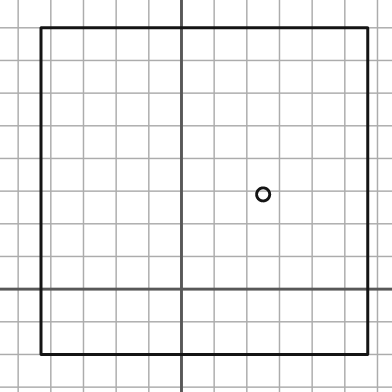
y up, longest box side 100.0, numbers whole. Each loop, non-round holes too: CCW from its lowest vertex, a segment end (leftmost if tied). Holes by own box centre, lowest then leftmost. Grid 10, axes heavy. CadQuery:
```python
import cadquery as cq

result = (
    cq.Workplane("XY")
    .moveTo(-43.0, -20.0)
    .lineTo(57.0, -20.0)
    .lineTo(57.0, 80.0)
    .lineTo(-43.0, 80.0)
    .close()
    .moveTo(25.0, 29.0)
    .circle(2.0)
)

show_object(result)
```